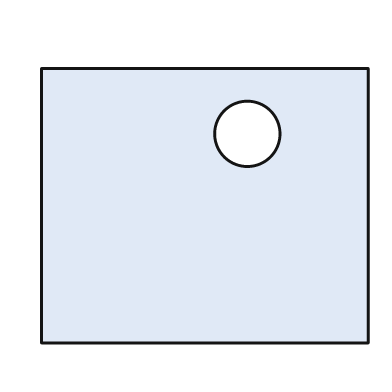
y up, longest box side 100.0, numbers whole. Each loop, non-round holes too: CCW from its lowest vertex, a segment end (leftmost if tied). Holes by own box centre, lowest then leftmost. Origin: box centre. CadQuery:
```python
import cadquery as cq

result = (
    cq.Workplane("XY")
    .moveTo(-50.0, -42.0)
    .lineTo(50.0, -42.0)
    .lineTo(50.0, 42.0)
    .lineTo(-50.0, 42.0)
    .close()
    .moveTo(13.0, 22.0)
    .circle(10.0)
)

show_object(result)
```